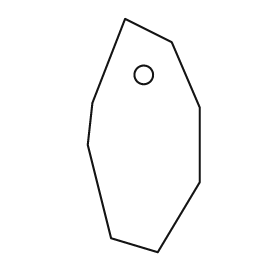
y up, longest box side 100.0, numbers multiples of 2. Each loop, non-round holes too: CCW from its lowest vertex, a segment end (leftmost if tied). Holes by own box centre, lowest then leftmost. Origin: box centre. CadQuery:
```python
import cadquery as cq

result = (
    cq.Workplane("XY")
    .moveTo(6.0, -50.0)
    .lineTo(24.0, -20.0)
    .lineTo(24.0, 12.0)
    .lineTo(12.0, 40.0)
    .lineTo(-8.0, 50.0)
    .lineTo(-22.0, 14.0)
    .lineTo(-24.0, -4.0)
    .lineTo(-14.0, -44.0)
    .close()
    .moveTo(0.0, 26.0)
    .circle(4.0)
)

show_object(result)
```